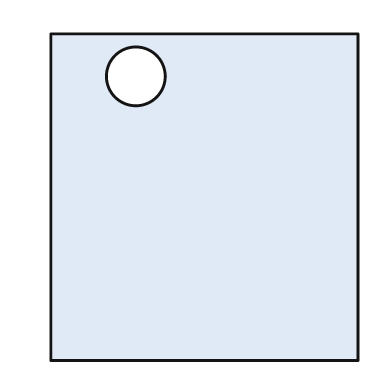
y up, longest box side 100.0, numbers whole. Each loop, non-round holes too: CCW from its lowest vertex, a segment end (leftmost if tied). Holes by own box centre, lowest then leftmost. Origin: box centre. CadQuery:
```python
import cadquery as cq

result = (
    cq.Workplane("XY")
    .moveTo(-47.0, -50.0)
    .lineTo(47.0, -50.0)
    .lineTo(47.0, 50.0)
    .lineTo(-47.0, 50.0)
    .close()
    .moveTo(-21.0, 37.0)
    .circle(9.0)
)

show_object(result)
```